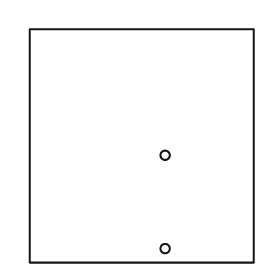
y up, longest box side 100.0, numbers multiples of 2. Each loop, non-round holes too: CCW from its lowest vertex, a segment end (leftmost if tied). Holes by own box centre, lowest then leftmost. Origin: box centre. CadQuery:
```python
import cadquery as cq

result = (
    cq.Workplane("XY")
    .moveTo(-48.0, -50.0)
    .lineTo(48.0, -50.0)
    .lineTo(48.0, 50.0)
    .lineTo(-48.0, 50.0)
    .close()
    .moveTo(10.0, -44.0)
    .circle(2.0)
    .moveTo(10.0, -4.0)
    .circle(2.0)
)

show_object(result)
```